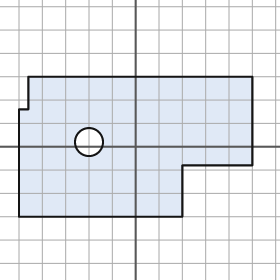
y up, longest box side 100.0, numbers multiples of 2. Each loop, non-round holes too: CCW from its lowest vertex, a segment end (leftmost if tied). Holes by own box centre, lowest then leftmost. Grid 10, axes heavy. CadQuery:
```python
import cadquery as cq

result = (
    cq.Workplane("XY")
    .moveTo(-50.0, -30.0)
    .lineTo(20.0, -30.0)
    .lineTo(20.0, -8.0)
    .lineTo(50.0, -8.0)
    .lineTo(50.0, 30.0)
    .lineTo(-46.0, 30.0)
    .lineTo(-46.0, 16.0)
    .lineTo(-50.0, 16.0)
    .close()
    .moveTo(-20.0, 2.0)
    .circle(6.0)
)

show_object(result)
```